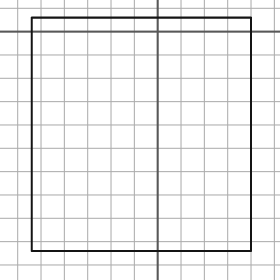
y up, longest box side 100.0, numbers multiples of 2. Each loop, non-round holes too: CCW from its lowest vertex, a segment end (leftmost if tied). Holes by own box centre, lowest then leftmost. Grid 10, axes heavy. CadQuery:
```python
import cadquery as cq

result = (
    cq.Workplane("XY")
    .moveTo(-54.0, -94.0)
    .lineTo(40.0, -94.0)
    .lineTo(40.0, 6.0)
    .lineTo(-54.0, 6.0)
    .close()
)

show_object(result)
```